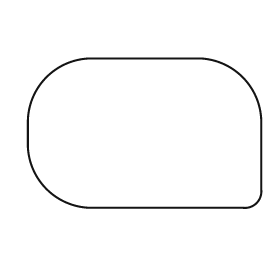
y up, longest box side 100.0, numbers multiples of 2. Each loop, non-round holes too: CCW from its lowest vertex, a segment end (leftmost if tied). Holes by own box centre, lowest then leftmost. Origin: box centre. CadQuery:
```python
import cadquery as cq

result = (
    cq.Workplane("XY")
    .moveTo(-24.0, -32.0)
    .lineTo(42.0, -32.0)
    .threePointArc((48.0, -30.0), (50.0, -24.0))
    .lineTo(50.0, 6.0)
    .threePointArc((42.0, 24.0), (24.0, 32.0))
    .lineTo(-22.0, 32.0)
    .threePointArc((-42.0, 24.0), (-50.0, 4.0))
    .lineTo(-50.0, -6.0)
    .threePointArc((-42.0, -24.0), (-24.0, -32.0))
    .close()
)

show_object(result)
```